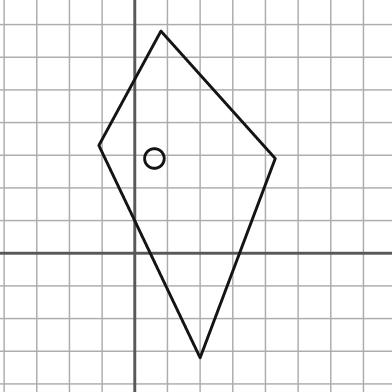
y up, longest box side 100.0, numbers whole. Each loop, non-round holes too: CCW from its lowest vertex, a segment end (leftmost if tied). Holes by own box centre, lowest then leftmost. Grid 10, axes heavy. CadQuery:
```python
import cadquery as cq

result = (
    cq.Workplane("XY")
    .moveTo(20.0, -32.0)
    .lineTo(43.0, 29.0)
    .lineTo(8.0, 68.0)
    .lineTo(-11.0, 33.0)
    .close()
    .moveTo(6.0, 29.0)
    .circle(3.0)
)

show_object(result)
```